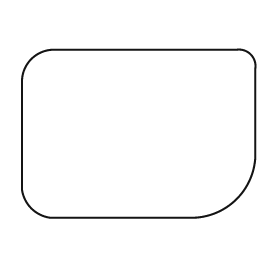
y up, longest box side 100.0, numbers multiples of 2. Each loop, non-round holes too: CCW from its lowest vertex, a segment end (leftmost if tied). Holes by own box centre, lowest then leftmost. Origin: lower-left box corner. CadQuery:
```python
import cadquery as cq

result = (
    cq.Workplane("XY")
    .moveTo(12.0, 0.0)
    .lineTo(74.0, 0.0)
    .threePointArc((92.0, 8.0), (100.0, 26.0))
    .lineTo(100.0, 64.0)
    .threePointArc((98.0, 70.0), (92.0, 72.0))
    .lineTo(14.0, 72.0)
    .threePointArc((4.0, 68.0), (0.0, 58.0))
    .lineTo(0.0, 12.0)
    .threePointArc((4.0, 4.0), (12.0, 0.0))
    .close()
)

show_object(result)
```